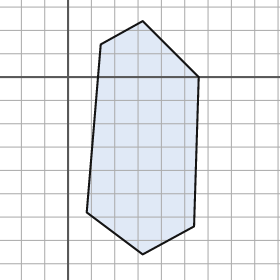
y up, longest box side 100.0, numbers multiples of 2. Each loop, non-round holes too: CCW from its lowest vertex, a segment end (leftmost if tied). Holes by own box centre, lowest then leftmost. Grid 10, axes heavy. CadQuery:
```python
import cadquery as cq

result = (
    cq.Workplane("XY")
    .moveTo(32.0, -76.0)
    .lineTo(54.0, -64.0)
    .lineTo(56.0, 0.0)
    .lineTo(32.0, 24.0)
    .lineTo(14.0, 14.0)
    .lineTo(8.0, -58.0)
    .close()
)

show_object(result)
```